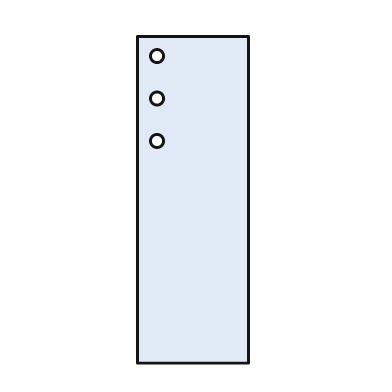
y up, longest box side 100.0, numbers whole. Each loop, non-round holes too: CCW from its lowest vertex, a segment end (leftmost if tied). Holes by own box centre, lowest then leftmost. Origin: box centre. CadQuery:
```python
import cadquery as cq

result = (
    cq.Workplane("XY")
    .moveTo(-17.0, -50.0)
    .lineTo(17.0, -50.0)
    .lineTo(17.0, 50.0)
    .lineTo(-17.0, 50.0)
    .close()
    .moveTo(-11.0, 18.0)
    .circle(2.0)
    .moveTo(-11.0, 31.0)
    .circle(2.0)
    .moveTo(-11.0, 44.0)
    .circle(2.0)
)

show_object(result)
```